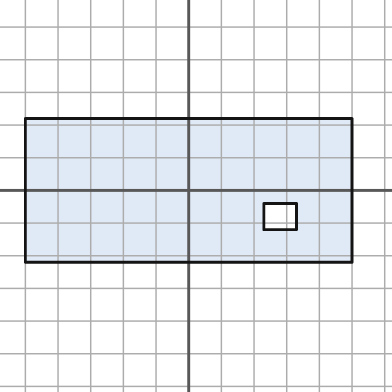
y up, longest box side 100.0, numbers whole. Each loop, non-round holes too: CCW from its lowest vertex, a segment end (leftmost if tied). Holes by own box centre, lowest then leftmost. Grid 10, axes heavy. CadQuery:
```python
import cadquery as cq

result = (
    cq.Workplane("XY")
    .moveTo(-50.0, -22.0)
    .lineTo(50.0, -22.0)
    .lineTo(50.0, 22.0)
    .lineTo(-50.0, 22.0)
    .close()
    .moveTo(23.0, -12.0)
    .lineTo(33.0, -12.0)
    .lineTo(33.0, -4.0)
    .lineTo(23.0, -4.0)
    .close()
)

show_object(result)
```